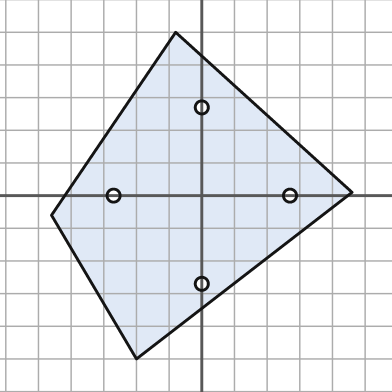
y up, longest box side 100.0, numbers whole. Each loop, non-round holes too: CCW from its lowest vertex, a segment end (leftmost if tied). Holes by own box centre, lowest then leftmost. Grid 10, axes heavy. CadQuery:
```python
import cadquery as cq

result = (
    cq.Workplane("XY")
    .moveTo(-20.0, -50.0)
    .lineTo(46.0, 1.0)
    .lineTo(-8.0, 50.0)
    .lineTo(-46.0, -6.0)
    .close()
    .moveTo(0.0, -27.0)
    .circle(2.0)
    .moveTo(-27.0, 0.0)
    .circle(2.0)
    .moveTo(27.0, 0.0)
    .circle(2.0)
    .moveTo(0.0, 27.0)
    .circle(2.0)
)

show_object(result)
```